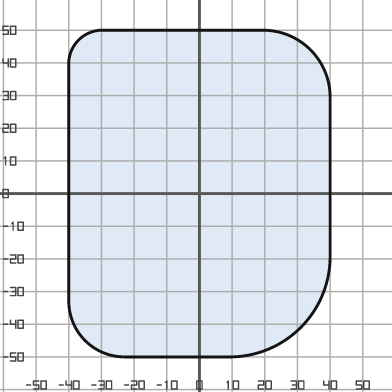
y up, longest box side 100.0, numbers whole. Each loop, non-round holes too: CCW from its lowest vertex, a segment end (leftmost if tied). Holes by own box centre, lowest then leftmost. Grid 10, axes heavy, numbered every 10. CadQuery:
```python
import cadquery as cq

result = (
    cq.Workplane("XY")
    .moveTo(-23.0, -50.0)
    .lineTo(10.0, -50.0)
    .threePointArc((31.0, -41.0), (40.0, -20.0))
    .lineTo(40.0, 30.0)
    .threePointArc((34.0, 44.0), (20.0, 50.0))
    .lineTo(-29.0, 50.0)
    .threePointArc((-37.0, 47.0), (-40.0, 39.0))
    .lineTo(-40.0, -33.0)
    .threePointArc((-35.0, -45.0), (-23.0, -50.0))
    .close()
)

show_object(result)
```